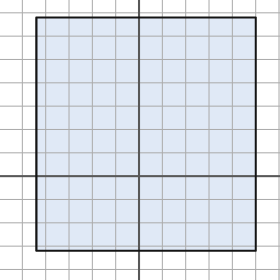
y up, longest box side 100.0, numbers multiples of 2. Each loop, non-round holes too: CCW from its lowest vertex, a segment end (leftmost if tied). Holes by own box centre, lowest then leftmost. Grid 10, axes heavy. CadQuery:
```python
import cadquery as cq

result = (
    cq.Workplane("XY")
    .moveTo(-44.0, -32.0)
    .lineTo(50.0, -32.0)
    .lineTo(50.0, 68.0)
    .lineTo(-44.0, 68.0)
    .close()
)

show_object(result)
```